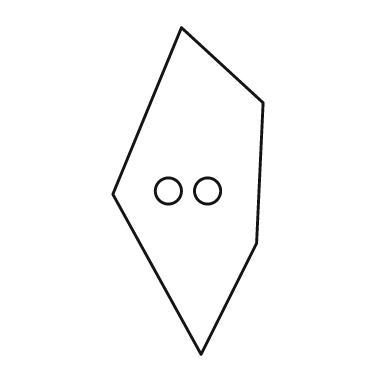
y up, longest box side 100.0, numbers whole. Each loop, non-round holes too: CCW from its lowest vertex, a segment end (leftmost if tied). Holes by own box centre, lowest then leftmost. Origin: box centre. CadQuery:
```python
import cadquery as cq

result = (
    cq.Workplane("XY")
    .moveTo(4.0, -50.0)
    .lineTo(21.0, -16.0)
    .lineTo(23.0, 27.0)
    .lineTo(-2.0, 50.0)
    .lineTo(-23.0, -1.0)
    .close()
    .moveTo(-6.0, 0.0)
    .circle(4.0)
    .moveTo(6.0, 0.0)
    .circle(4.0)
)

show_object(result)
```